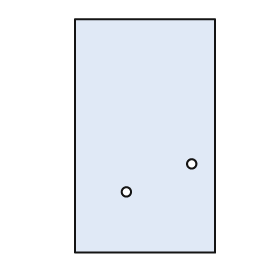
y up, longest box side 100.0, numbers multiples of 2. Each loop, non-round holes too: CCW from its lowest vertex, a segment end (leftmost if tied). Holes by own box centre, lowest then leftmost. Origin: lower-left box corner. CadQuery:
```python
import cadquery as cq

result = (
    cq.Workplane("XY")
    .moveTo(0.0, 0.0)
    .lineTo(60.0, 0.0)
    .lineTo(60.0, 100.0)
    .lineTo(0.0, 100.0)
    .close()
    .moveTo(22.0, 26.0)
    .circle(2.0)
    .moveTo(50.0, 38.0)
    .circle(2.0)
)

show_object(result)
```